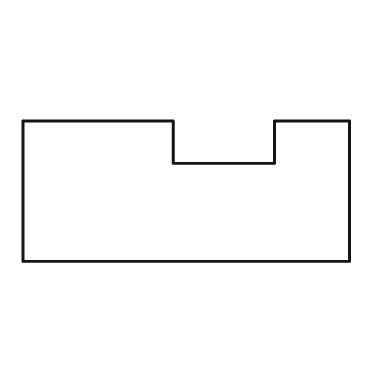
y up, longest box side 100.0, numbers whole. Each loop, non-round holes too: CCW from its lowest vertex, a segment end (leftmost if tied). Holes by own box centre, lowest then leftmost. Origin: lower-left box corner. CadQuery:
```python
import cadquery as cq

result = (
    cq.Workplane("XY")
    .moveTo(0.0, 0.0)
    .lineTo(100.0, 0.0)
    .lineTo(100.0, 43.0)
    .lineTo(77.0, 43.0)
    .lineTo(77.0, 30.0)
    .lineTo(46.0, 30.0)
    .lineTo(46.0, 43.0)
    .lineTo(0.0, 43.0)
    .close()
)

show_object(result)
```